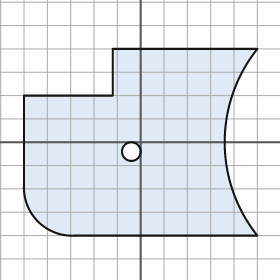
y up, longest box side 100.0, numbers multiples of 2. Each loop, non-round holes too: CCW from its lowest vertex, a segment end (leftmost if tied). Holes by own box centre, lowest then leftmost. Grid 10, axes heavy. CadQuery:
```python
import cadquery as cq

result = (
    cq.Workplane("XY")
    .moveTo(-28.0, -40.0)
    .lineTo(50.0, -40.0)
    .threePointArc((36.0, 0.0), (50.0, 40.0))
    .lineTo(-12.0, 40.0)
    .lineTo(-12.0, 20.0)
    .lineTo(-50.0, 20.0)
    .lineTo(-50.0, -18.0)
    .threePointArc((-44.0, -34.0), (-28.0, -40.0))
    .close()
    .moveTo(-4.0, -4.0)
    .circle(4.0)
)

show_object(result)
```